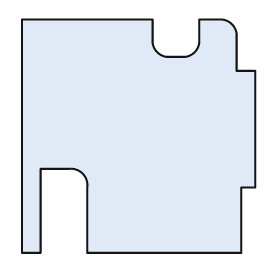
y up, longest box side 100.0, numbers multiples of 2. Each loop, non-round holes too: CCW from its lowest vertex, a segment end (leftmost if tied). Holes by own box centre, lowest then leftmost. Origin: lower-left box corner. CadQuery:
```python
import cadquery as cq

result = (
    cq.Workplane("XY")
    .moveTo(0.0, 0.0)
    .lineTo(8.0, 0.0)
    .lineTo(8.0, 36.0)
    .lineTo(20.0, 36.0)
    .threePointArc((26.0, 34.0), (28.0, 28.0))
    .lineTo(28.0, 0.0)
    .lineTo(94.0, 0.0)
    .lineTo(94.0, 28.0)
    .lineTo(100.0, 28.0)
    .lineTo(100.0, 78.0)
    .lineTo(92.0, 78.0)
    .lineTo(92.0, 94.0)
    .threePointArc((90.0, 98.0), (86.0, 100.0))
    .lineTo(76.0, 100.0)
    .lineTo(76.0, 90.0)
    .threePointArc((74.0, 86.0), (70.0, 84.0))
    .lineTo(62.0, 84.0)
    .threePointArc((58.0, 86.0), (56.0, 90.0))
    .lineTo(56.0, 100.0)
    .lineTo(0.0, 100.0)
    .close()
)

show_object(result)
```